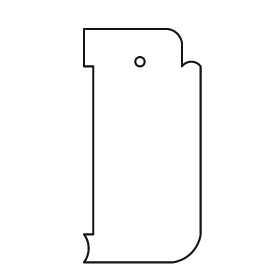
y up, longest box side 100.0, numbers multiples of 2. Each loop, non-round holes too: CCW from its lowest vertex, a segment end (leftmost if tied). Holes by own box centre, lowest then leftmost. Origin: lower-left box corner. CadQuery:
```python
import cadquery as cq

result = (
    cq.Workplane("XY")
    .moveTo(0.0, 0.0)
    .lineTo(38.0, 0.0)
    .threePointArc((46.0, 4.0), (50.0, 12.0))
    .lineTo(50.0, 84.0)
    .threePointArc((46.0, 86.0), (42.0, 84.0))
    .lineTo(42.0, 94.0)
    .threePointArc((40.0, 98.0), (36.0, 100.0))
    .lineTo(0.0, 100.0)
    .lineTo(0.0, 84.0)
    .lineTo(4.0, 84.0)
    .lineTo(4.0, 12.0)
    .lineTo(0.0, 12.0)
    .threePointArc((2.0, 6.0), (0.0, 0.0))
    .close()
    .moveTo(24.0, 86.0)
    .circle(2.0)
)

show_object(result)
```